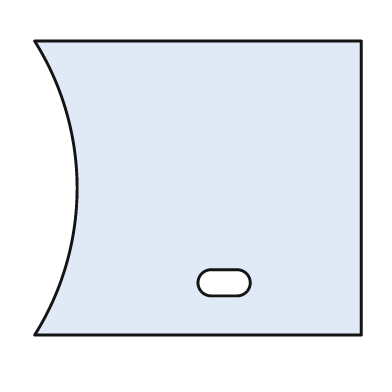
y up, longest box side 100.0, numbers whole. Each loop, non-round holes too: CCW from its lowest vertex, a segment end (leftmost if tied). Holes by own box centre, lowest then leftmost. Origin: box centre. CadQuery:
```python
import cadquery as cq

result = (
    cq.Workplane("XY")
    .moveTo(-50.0, -45.0)
    .lineTo(50.0, -45.0)
    .lineTo(50.0, 45.0)
    .lineTo(-50.0, 45.0)
    .threePointArc((-37.0, 0.0), (-50.0, -45.0))
    .close()
    .moveTo(4.0, -33.0)
    .lineTo(12.0, -33.0)
    .threePointArc((16.0, -29.0), (12.0, -25.0))
    .lineTo(4.0, -25.0)
    .threePointArc((0.0, -29.0), (4.0, -33.0))
    .close()
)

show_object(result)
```